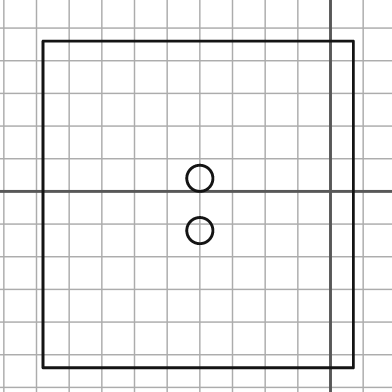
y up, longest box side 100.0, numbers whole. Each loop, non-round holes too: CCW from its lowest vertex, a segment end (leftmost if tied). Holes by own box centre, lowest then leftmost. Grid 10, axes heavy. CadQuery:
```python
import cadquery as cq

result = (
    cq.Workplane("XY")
    .moveTo(-88.0, -54.0)
    .lineTo(7.0, -54.0)
    .lineTo(7.0, 46.0)
    .lineTo(-88.0, 46.0)
    .close()
    .moveTo(-40.0, -12.0)
    .circle(4.0)
    .moveTo(-40.0, 4.0)
    .circle(4.0)
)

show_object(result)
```